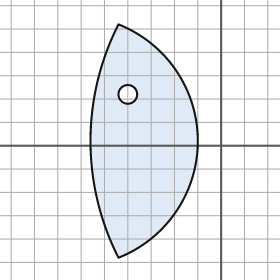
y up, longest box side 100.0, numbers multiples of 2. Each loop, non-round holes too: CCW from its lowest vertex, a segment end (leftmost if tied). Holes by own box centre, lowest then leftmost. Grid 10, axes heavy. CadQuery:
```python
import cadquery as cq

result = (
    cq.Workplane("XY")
    .moveTo(-44.0, -48.0)
    .threePointArc((-10.0, 2.0), (-44.0, 52.0))
    .threePointArc((-56.0, 2.0), (-44.0, -48.0))
    .close()
    .moveTo(-40.0, 22.0)
    .circle(4.0)
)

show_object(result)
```